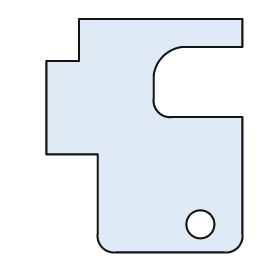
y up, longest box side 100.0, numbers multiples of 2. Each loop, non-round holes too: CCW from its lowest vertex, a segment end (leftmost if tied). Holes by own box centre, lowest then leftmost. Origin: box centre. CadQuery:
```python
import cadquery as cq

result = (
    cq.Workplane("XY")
    .moveTo(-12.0, -50.0)
    .lineTo(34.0, -50.0)
    .threePointArc((40.0, -48.0), (42.0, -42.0))
    .lineTo(42.0, 8.0)
    .lineTo(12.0, 8.0)
    .threePointArc((6.0, 10.0), (4.0, 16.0))
    .lineTo(4.0, 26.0)
    .threePointArc((8.0, 34.0), (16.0, 38.0))
    .lineTo(42.0, 38.0)
    .lineTo(42.0, 50.0)
    .lineTo(-28.0, 50.0)
    .lineTo(-28.0, 32.0)
    .lineTo(-42.0, 32.0)
    .lineTo(-42.0, -8.0)
    .lineTo(-20.0, -8.0)
    .lineTo(-20.0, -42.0)
    .threePointArc((-18.0, -48.0), (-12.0, -50.0))
    .close()
    .moveTo(24.0, -38.0)
    .circle(6.0)
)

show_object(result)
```